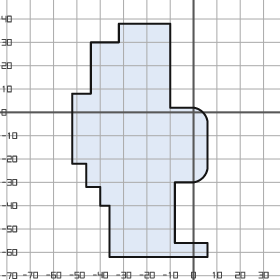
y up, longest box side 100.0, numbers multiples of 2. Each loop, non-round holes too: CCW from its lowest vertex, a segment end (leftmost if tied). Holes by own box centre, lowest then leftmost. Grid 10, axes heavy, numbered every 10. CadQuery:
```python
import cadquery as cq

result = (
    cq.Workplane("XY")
    .moveTo(-36.0, -62.0)
    .lineTo(6.0, -62.0)
    .lineTo(6.0, -56.0)
    .lineTo(-8.0, -56.0)
    .lineTo(-8.0, -30.0)
    .lineTo(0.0, -30.0)
    .threePointArc((4.0, -28.0), (6.0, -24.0))
    .lineTo(6.0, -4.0)
    .threePointArc((4.0, 0.0), (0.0, 2.0))
    .lineTo(-10.0, 2.0)
    .lineTo(-10.0, 38.0)
    .lineTo(-32.0, 38.0)
    .lineTo(-32.0, 30.0)
    .lineTo(-44.0, 30.0)
    .lineTo(-44.0, 8.0)
    .lineTo(-52.0, 8.0)
    .lineTo(-52.0, -22.0)
    .lineTo(-46.0, -22.0)
    .lineTo(-46.0, -32.0)
    .lineTo(-40.0, -32.0)
    .lineTo(-40.0, -40.0)
    .lineTo(-36.0, -40.0)
    .close()
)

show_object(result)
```